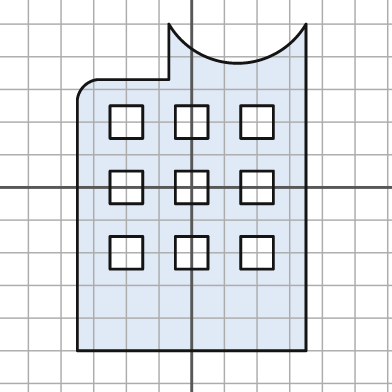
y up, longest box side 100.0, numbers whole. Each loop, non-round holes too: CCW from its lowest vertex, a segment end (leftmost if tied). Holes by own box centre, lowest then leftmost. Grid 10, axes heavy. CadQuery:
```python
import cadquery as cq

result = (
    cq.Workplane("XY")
    .moveTo(-35.0, -50.0)
    .lineTo(35.0, -50.0)
    .lineTo(35.0, 50.0)
    .threePointArc((14.0, 38.0), (-7.0, 50.0))
    .lineTo(-7.0, 33.0)
    .lineTo(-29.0, 33.0)
    .threePointArc((-33.0, 31.0), (-35.0, 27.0))
    .close()
    .moveTo(-25.0, -25.0)
    .lineTo(-15.0, -25.0)
    .lineTo(-15.0, -15.0)
    .lineTo(-25.0, -15.0)
    .close()
    .moveTo(-5.0, -25.0)
    .lineTo(5.0, -25.0)
    .lineTo(5.0, -15.0)
    .lineTo(-5.0, -15.0)
    .close()
    .moveTo(15.0, -25.0)
    .lineTo(25.0, -25.0)
    .lineTo(25.0, -15.0)
    .lineTo(15.0, -15.0)
    .close()
    .moveTo(-25.0, -5.0)
    .lineTo(-15.0, -5.0)
    .lineTo(-15.0, 5.0)
    .lineTo(-25.0, 5.0)
    .close()
    .moveTo(-5.0, -5.0)
    .lineTo(5.0, -5.0)
    .lineTo(5.0, 5.0)
    .lineTo(-5.0, 5.0)
    .close()
    .moveTo(15.0, -5.0)
    .lineTo(25.0, -5.0)
    .lineTo(25.0, 5.0)
    .lineTo(15.0, 5.0)
    .close()
    .moveTo(-25.0, 15.0)
    .lineTo(-15.0, 15.0)
    .lineTo(-15.0, 25.0)
    .lineTo(-25.0, 25.0)
    .close()
    .moveTo(-5.0, 15.0)
    .lineTo(5.0, 15.0)
    .lineTo(5.0, 25.0)
    .lineTo(-5.0, 25.0)
    .close()
    .moveTo(15.0, 15.0)
    .lineTo(25.0, 15.0)
    .lineTo(25.0, 25.0)
    .lineTo(15.0, 25.0)
    .close()
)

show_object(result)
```